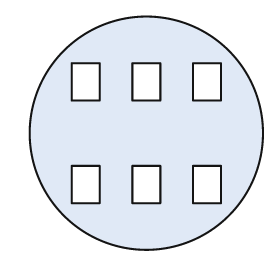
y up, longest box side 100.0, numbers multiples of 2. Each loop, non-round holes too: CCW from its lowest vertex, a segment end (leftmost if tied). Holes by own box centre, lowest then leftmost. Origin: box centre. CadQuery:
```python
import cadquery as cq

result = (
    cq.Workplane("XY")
    .moveTo(0.0, 0.0)
    .circle(50.0)
    .moveTo(-32.0, -30.0)
    .lineTo(-20.0, -30.0)
    .lineTo(-20.0, -14.0)
    .lineTo(-32.0, -14.0)
    .close()
    .moveTo(-6.0, -30.0)
    .lineTo(6.0, -30.0)
    .lineTo(6.0, -14.0)
    .lineTo(-6.0, -14.0)
    .close()
    .moveTo(20.0, -30.0)
    .lineTo(32.0, -30.0)
    .lineTo(32.0, -14.0)
    .lineTo(20.0, -14.0)
    .close()
    .moveTo(-32.0, 14.0)
    .lineTo(-20.0, 14.0)
    .lineTo(-20.0, 30.0)
    .lineTo(-32.0, 30.0)
    .close()
    .moveTo(-6.0, 14.0)
    .lineTo(6.0, 14.0)
    .lineTo(6.0, 30.0)
    .lineTo(-6.0, 30.0)
    .close()
    .moveTo(20.0, 14.0)
    .lineTo(32.0, 14.0)
    .lineTo(32.0, 30.0)
    .lineTo(20.0, 30.0)
    .close()
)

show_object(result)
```